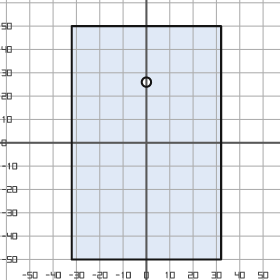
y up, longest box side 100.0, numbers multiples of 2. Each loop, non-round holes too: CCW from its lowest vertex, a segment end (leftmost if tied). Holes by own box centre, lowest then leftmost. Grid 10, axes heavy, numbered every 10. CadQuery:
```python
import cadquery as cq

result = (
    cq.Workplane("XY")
    .moveTo(-32.0, -50.0)
    .lineTo(32.0, -50.0)
    .lineTo(32.0, 50.0)
    .lineTo(-32.0, 50.0)
    .close()
    .moveTo(0.0, 26.0)
    .circle(2.0)
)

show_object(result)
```